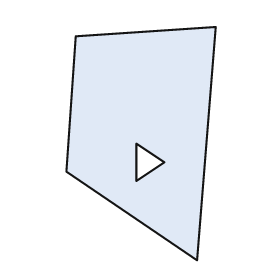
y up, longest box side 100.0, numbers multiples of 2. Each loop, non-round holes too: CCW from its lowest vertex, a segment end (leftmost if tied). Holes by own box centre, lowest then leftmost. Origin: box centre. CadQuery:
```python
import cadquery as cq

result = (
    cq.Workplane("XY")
    .moveTo(24.0, -50.0)
    .lineTo(32.0, 50.0)
    .lineTo(-28.0, 46.0)
    .lineTo(-32.0, -12.0)
    .close()
    .moveTo(-2.0, -16.0)
    .lineTo(10.0, -8.0)
    .lineTo(-2.0, 0.0)
    .close()
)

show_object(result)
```